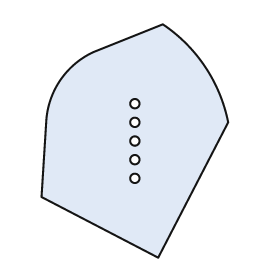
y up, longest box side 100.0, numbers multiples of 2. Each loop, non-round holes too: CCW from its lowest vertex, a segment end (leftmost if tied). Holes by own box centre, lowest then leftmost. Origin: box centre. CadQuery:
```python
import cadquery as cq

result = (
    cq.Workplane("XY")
    .moveTo(10.0, -50.0)
    .lineTo(40.0, 8.0)
    .threePointArc((30.0, 32.0), (12.0, 50.0))
    .lineTo(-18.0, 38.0)
    .threePointArc((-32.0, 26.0), (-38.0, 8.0))
    .lineTo(-40.0, -24.0)
    .close()
    .moveTo(0.0, -16.0)
    .circle(2.0)
    .moveTo(0.0, -8.0)
    .circle(2.0)
    .moveTo(0.0, 0.0)
    .circle(2.0)
    .moveTo(0.0, 8.0)
    .circle(2.0)
    .moveTo(0.0, 16.0)
    .circle(2.0)
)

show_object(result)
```